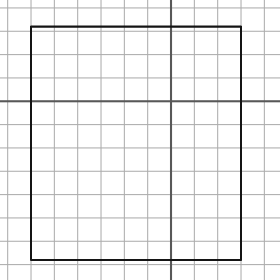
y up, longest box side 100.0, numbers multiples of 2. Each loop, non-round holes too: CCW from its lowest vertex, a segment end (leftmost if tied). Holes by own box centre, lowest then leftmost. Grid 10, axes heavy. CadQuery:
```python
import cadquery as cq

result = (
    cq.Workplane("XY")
    .moveTo(-60.0, -68.0)
    .lineTo(30.0, -68.0)
    .lineTo(30.0, 32.0)
    .lineTo(-60.0, 32.0)
    .close()
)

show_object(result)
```